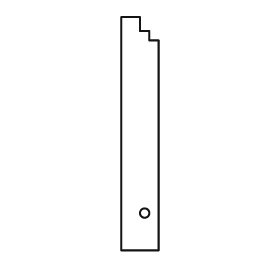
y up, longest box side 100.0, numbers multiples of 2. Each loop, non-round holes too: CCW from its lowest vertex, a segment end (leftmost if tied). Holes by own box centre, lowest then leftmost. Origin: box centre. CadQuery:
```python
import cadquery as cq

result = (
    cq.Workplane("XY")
    .moveTo(-8.0, -50.0)
    .lineTo(8.0, -50.0)
    .lineTo(8.0, 40.0)
    .lineTo(4.0, 40.0)
    .lineTo(4.0, 44.0)
    .lineTo(0.0, 44.0)
    .lineTo(0.0, 50.0)
    .lineTo(-8.0, 50.0)
    .close()
    .moveTo(2.0, -34.0)
    .circle(2.0)
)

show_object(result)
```